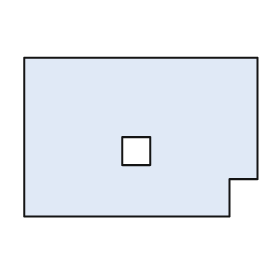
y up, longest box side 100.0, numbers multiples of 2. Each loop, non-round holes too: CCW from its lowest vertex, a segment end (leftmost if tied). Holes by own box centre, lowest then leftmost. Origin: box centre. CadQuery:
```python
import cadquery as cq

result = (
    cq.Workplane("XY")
    .moveTo(-50.0, -34.0)
    .lineTo(38.0, -34.0)
    .lineTo(38.0, -18.0)
    .lineTo(50.0, -18.0)
    .lineTo(50.0, 34.0)
    .lineTo(-50.0, 34.0)
    .close()
    .moveTo(-8.0, -12.0)
    .lineTo(4.0, -12.0)
    .lineTo(4.0, 0.0)
    .lineTo(-8.0, 0.0)
    .close()
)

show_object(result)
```